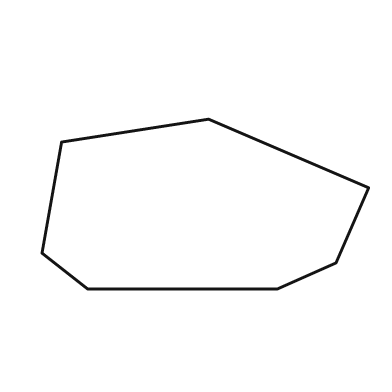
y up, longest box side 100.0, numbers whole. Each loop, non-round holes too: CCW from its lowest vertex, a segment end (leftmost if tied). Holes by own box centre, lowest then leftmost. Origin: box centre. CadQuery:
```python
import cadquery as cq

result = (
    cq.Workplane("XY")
    .moveTo(-36.0, -26.0)
    .lineTo(22.0, -26.0)
    .lineTo(40.0, -18.0)
    .lineTo(50.0, 5.0)
    .lineTo(1.0, 26.0)
    .lineTo(-44.0, 19.0)
    .lineTo(-50.0, -15.0)
    .close()
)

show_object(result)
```